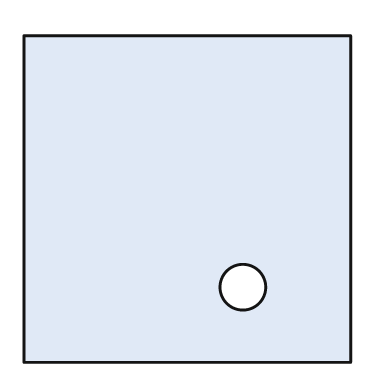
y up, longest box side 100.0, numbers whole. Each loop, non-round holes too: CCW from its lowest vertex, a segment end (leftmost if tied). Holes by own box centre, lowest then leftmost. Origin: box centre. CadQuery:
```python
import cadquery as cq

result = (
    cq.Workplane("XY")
    .moveTo(-50.0, -50.0)
    .lineTo(50.0, -50.0)
    .lineTo(50.0, 50.0)
    .lineTo(-50.0, 50.0)
    .close()
    .moveTo(17.0, -27.0)
    .circle(7.0)
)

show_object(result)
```